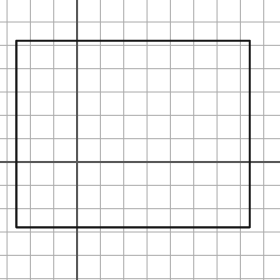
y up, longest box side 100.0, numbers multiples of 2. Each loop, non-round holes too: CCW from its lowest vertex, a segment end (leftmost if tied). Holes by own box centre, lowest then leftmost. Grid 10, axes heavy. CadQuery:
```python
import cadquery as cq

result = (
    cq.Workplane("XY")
    .moveTo(-26.0, -28.0)
    .lineTo(74.0, -28.0)
    .lineTo(74.0, 52.0)
    .lineTo(-26.0, 52.0)
    .close()
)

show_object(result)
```